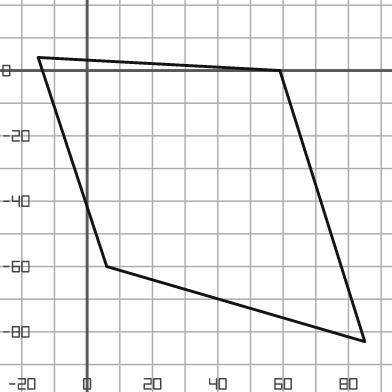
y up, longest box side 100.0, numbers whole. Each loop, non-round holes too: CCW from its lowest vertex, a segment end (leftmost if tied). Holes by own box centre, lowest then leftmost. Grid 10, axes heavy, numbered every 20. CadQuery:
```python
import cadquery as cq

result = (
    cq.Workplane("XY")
    .moveTo(85.0, -83.0)
    .lineTo(59.0, 0.0)
    .lineTo(-15.0, 4.0)
    .lineTo(6.0, -60.0)
    .close()
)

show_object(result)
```